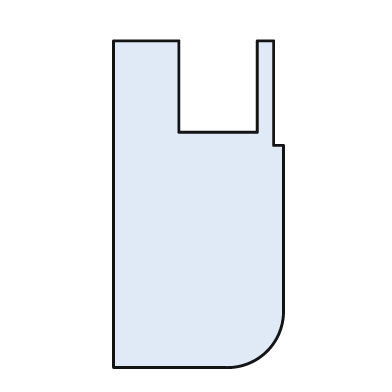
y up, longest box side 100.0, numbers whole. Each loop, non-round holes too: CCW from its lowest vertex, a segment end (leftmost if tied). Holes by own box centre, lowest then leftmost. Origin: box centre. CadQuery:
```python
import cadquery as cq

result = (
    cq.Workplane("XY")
    .moveTo(-26.0, -50.0)
    .lineTo(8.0, -50.0)
    .threePointArc((21.0, -45.0), (26.0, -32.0))
    .lineTo(26.0, 18.0)
    .lineTo(23.0, 18.0)
    .lineTo(23.0, 50.0)
    .lineTo(18.0, 50.0)
    .lineTo(18.0, 22.0)
    .lineTo(-6.0, 22.0)
    .lineTo(-6.0, 50.0)
    .lineTo(-26.0, 50.0)
    .close()
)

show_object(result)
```